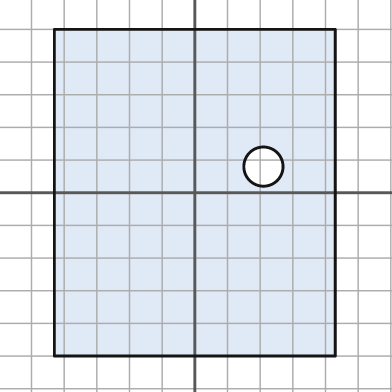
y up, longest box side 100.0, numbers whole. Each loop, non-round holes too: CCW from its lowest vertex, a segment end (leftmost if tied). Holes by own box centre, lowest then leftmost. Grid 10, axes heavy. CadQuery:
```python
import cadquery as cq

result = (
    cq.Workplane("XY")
    .moveTo(-43.0, -50.0)
    .lineTo(43.0, -50.0)
    .lineTo(43.0, 50.0)
    .lineTo(-43.0, 50.0)
    .close()
    .moveTo(21.0, 8.0)
    .circle(6.0)
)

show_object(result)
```